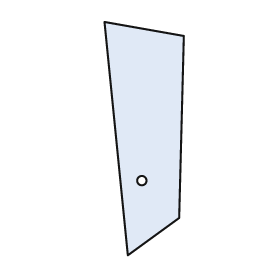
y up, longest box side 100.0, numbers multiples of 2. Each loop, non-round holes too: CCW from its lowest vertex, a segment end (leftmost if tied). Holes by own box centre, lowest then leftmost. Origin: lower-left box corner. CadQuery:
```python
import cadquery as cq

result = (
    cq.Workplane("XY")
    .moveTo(10.0, 0.0)
    .lineTo(32.0, 16.0)
    .lineTo(34.0, 94.0)
    .lineTo(0.0, 100.0)
    .close()
    .moveTo(16.0, 32.0)
    .circle(2.0)
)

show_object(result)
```